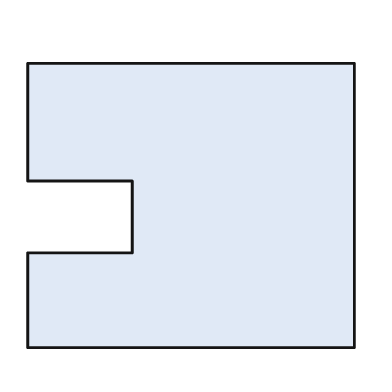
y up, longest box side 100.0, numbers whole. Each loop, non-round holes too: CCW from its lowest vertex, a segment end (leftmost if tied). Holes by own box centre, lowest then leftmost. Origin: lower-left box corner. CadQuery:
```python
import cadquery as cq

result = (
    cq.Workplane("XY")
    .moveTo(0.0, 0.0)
    .lineTo(100.0, 0.0)
    .lineTo(100.0, 87.0)
    .lineTo(0.0, 87.0)
    .lineTo(0.0, 51.0)
    .lineTo(32.0, 51.0)
    .lineTo(32.0, 29.0)
    .lineTo(0.0, 29.0)
    .close()
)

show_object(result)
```